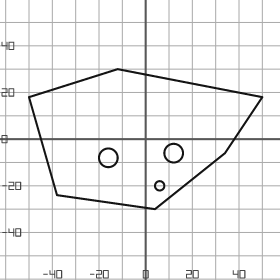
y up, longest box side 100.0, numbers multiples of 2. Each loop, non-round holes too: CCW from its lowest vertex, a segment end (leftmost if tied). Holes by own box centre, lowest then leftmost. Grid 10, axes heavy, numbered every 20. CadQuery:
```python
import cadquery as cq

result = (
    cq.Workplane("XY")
    .moveTo(4.0, -30.0)
    .lineTo(34.0, -6.0)
    .lineTo(50.0, 18.0)
    .lineTo(-12.0, 30.0)
    .lineTo(-50.0, 18.0)
    .lineTo(-38.0, -24.0)
    .close()
    .moveTo(6.0, -20.0)
    .circle(2.0)
    .moveTo(-16.0, -8.0)
    .circle(4.0)
    .moveTo(12.0, -6.0)
    .circle(4.0)
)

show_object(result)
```